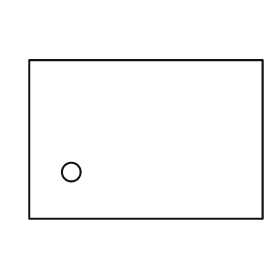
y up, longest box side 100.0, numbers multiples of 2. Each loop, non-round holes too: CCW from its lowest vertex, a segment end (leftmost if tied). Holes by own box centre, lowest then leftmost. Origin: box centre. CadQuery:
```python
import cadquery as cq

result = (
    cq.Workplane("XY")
    .moveTo(-50.0, -34.0)
    .lineTo(50.0, -34.0)
    .lineTo(50.0, 34.0)
    .lineTo(-50.0, 34.0)
    .close()
    .moveTo(-32.0, -14.0)
    .circle(4.0)
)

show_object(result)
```